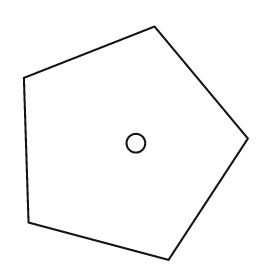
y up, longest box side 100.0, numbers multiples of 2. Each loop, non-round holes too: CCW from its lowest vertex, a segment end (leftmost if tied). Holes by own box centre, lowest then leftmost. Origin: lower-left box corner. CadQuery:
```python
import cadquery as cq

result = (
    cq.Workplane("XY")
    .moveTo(62.0, 0.0)
    .lineTo(96.0, 52.0)
    .lineTo(56.0, 100.0)
    .lineTo(0.0, 78.0)
    .lineTo(2.0, 16.0)
    .close()
    .moveTo(48.0, 50.0)
    .circle(4.0)
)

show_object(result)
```